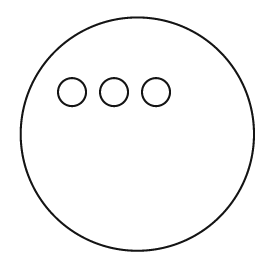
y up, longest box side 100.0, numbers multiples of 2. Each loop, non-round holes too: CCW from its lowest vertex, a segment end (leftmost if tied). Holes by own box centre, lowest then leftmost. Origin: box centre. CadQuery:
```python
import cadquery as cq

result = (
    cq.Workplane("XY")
    .moveTo(0.0, 0.0)
    .circle(50.0)
    .moveTo(-28.0, 18.0)
    .circle(6.0)
    .moveTo(-10.0, 18.0)
    .circle(6.0)
    .moveTo(8.0, 18.0)
    .circle(6.0)
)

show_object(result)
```